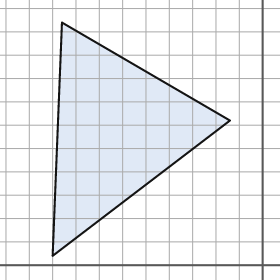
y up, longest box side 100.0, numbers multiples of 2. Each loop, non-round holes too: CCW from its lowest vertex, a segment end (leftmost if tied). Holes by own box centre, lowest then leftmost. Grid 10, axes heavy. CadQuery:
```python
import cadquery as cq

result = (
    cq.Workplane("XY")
    .moveTo(-90.0, 4.0)
    .lineTo(-14.0, 62.0)
    .lineTo(-86.0, 104.0)
    .close()
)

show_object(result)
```